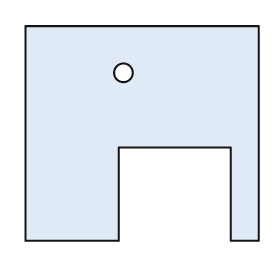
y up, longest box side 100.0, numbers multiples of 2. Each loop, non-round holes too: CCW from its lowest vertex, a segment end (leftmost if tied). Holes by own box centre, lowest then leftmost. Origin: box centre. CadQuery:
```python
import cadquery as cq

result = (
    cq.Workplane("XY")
    .moveTo(-50.0, -46.0)
    .lineTo(-10.0, -46.0)
    .lineTo(-10.0, -6.0)
    .lineTo(38.0, -6.0)
    .lineTo(38.0, -46.0)
    .lineTo(50.0, -46.0)
    .lineTo(50.0, 46.0)
    .lineTo(-50.0, 46.0)
    .close()
    .moveTo(-8.0, 26.0)
    .circle(4.0)
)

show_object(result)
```